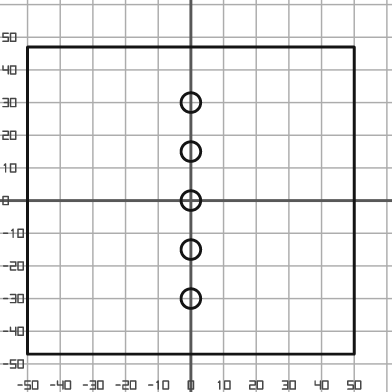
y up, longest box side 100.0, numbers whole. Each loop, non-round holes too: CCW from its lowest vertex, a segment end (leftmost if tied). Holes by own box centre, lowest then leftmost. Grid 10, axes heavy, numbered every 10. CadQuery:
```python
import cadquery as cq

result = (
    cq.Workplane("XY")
    .moveTo(-50.0, -47.0)
    .lineTo(50.0, -47.0)
    .lineTo(50.0, 47.0)
    .lineTo(-50.0, 47.0)
    .close()
    .moveTo(0.0, -30.0)
    .circle(3.0)
    .moveTo(0.0, -15.0)
    .circle(3.0)
    .moveTo(0.0, 0.0)
    .circle(3.0)
    .moveTo(0.0, 15.0)
    .circle(3.0)
    .moveTo(0.0, 30.0)
    .circle(3.0)
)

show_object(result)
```